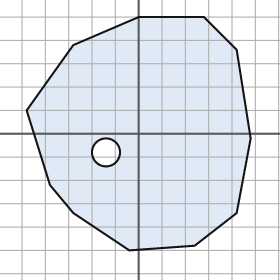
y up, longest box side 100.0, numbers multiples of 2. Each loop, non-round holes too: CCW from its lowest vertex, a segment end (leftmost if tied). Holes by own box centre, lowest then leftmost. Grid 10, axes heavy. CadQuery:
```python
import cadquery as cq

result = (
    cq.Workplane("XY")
    .moveTo(-4.0, -50.0)
    .lineTo(24.0, -48.0)
    .lineTo(42.0, -34.0)
    .lineTo(48.0, -2.0)
    .lineTo(42.0, 36.0)
    .lineTo(28.0, 50.0)
    .lineTo(0.0, 50.0)
    .lineTo(-28.0, 38.0)
    .lineTo(-48.0, 10.0)
    .lineTo(-38.0, -22.0)
    .lineTo(-28.0, -34.0)
    .close()
    .moveTo(-14.0, -8.0)
    .circle(6.0)
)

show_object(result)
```